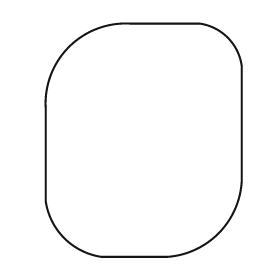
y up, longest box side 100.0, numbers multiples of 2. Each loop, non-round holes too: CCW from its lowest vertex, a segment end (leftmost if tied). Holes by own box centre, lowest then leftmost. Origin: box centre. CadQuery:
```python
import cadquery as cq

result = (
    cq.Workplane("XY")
    .moveTo(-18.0, -50.0)
    .lineTo(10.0, -50.0)
    .threePointArc((32.0, -40.0), (42.0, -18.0))
    .lineTo(42.0, 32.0)
    .threePointArc((36.0, 44.0), (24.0, 50.0))
    .lineTo(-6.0, 50.0)
    .threePointArc((-32.0, 40.0), (-42.0, 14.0))
    .lineTo(-42.0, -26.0)
    .threePointArc((-34.0, -42.0), (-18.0, -50.0))
    .close()
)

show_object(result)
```